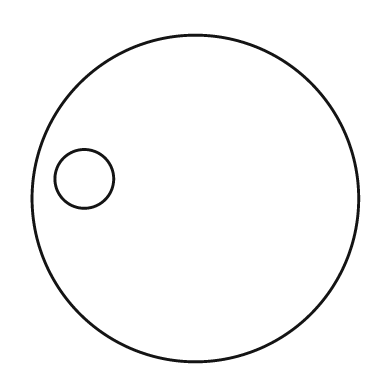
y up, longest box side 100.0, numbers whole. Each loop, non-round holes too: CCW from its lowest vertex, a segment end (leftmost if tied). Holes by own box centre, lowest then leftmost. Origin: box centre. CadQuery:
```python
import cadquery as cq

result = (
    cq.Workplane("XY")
    .moveTo(0.0, 0.0)
    .circle(50.0)
    .moveTo(-34.0, 6.0)
    .circle(9.0)
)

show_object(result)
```